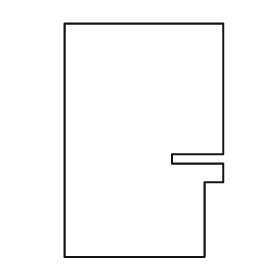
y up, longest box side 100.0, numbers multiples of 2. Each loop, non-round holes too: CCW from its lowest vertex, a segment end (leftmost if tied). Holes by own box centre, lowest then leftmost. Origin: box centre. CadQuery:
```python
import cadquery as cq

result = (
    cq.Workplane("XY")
    .moveTo(-34.0, -50.0)
    .lineTo(26.0, -50.0)
    .lineTo(26.0, -18.0)
    .lineTo(34.0, -18.0)
    .lineTo(34.0, -10.0)
    .lineTo(12.0, -10.0)
    .lineTo(12.0, -6.0)
    .lineTo(34.0, -6.0)
    .lineTo(34.0, 50.0)
    .lineTo(-34.0, 50.0)
    .close()
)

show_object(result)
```